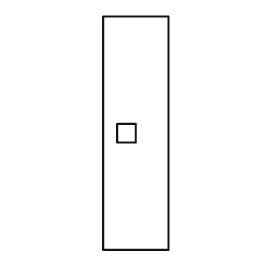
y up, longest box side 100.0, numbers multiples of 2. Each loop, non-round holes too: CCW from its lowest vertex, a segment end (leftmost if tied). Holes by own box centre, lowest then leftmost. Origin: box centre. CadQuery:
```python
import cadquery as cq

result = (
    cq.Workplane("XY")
    .moveTo(-14.0, -50.0)
    .lineTo(14.0, -50.0)
    .lineTo(14.0, 50.0)
    .lineTo(-14.0, 50.0)
    .close()
    .moveTo(-8.0, -4.0)
    .lineTo(0.0, -4.0)
    .lineTo(0.0, 4.0)
    .lineTo(-8.0, 4.0)
    .close()
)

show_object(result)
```